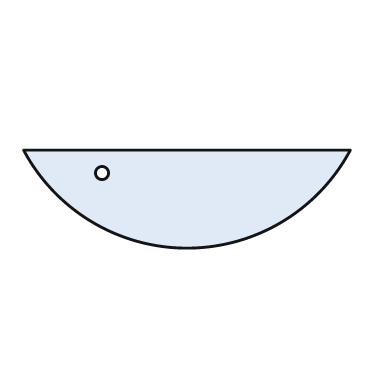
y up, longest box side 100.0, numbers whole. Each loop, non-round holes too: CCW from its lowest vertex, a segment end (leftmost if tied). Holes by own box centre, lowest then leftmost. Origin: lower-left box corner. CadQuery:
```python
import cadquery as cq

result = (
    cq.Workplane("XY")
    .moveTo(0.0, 30.0)
    .threePointArc((50.0, 0.0), (100.0, 30.0))
    .close()
    .moveTo(24.0, 23.0)
    .circle(2.0)
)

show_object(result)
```